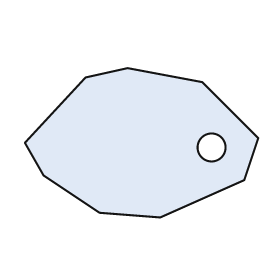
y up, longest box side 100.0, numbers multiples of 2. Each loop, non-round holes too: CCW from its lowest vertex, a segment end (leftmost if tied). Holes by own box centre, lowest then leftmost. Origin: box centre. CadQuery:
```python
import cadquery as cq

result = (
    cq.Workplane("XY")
    .moveTo(8.0, -32.0)
    .lineTo(44.0, -16.0)
    .lineTo(50.0, 2.0)
    .lineTo(26.0, 26.0)
    .lineTo(-6.0, 32.0)
    .lineTo(-24.0, 28.0)
    .lineTo(-50.0, 0.0)
    .lineTo(-42.0, -14.0)
    .lineTo(-18.0, -30.0)
    .close()
    .moveTo(30.0, -2.0)
    .circle(6.0)
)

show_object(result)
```